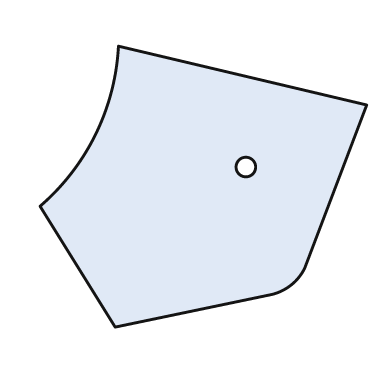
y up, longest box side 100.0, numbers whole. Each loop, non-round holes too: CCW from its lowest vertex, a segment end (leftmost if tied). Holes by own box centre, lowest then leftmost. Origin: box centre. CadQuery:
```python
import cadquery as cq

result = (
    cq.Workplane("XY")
    .moveTo(-27.0, -43.0)
    .lineTo(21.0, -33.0)
    .threePointArc((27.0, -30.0), (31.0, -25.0))
    .lineTo(50.0, 25.0)
    .lineTo(-26.0, 43.0)
    .threePointArc((-33.0, 16.0), (-50.0, -6.0))
    .close()
    .moveTo(13.0, 6.0)
    .circle(3.0)
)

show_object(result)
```